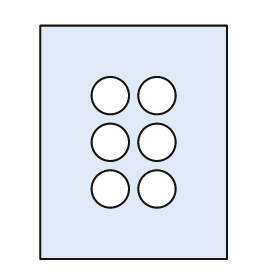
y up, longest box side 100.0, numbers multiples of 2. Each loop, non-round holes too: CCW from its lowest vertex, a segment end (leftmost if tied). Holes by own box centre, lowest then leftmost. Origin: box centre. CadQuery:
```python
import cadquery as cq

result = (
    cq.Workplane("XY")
    .moveTo(-40.0, -50.0)
    .lineTo(40.0, -50.0)
    .lineTo(40.0, 50.0)
    .lineTo(-40.0, 50.0)
    .close()
    .moveTo(-10.0, -20.0)
    .circle(8.0)
    .moveTo(10.0, -20.0)
    .circle(8.0)
    .moveTo(-10.0, 0.0)
    .circle(8.0)
    .moveTo(10.0, 0.0)
    .circle(8.0)
    .moveTo(-10.0, 20.0)
    .circle(8.0)
    .moveTo(10.0, 20.0)
    .circle(8.0)
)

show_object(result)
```